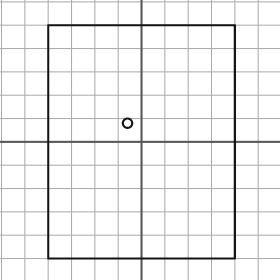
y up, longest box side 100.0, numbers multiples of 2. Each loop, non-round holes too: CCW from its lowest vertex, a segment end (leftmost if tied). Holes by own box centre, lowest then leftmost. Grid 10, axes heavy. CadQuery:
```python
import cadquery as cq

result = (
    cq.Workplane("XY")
    .moveTo(-40.0, -50.0)
    .lineTo(40.0, -50.0)
    .lineTo(40.0, 50.0)
    .lineTo(-40.0, 50.0)
    .close()
    .moveTo(-6.0, 8.0)
    .circle(2.0)
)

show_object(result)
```